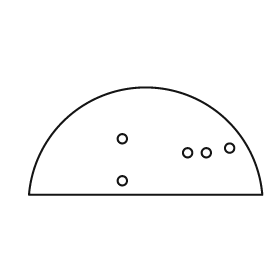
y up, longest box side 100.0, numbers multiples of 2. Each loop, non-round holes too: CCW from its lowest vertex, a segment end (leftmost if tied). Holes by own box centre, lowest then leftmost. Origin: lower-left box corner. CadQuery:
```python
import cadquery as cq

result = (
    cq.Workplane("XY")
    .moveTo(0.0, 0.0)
    .lineTo(100.0, 0.0)
    .threePointArc((50.0, 46.0), (0.0, 0.0))
    .close()
    .moveTo(40.0, 6.0)
    .circle(2.0)
    .moveTo(68.0, 18.0)
    .circle(2.0)
    .moveTo(76.0, 18.0)
    .circle(2.0)
    .moveTo(86.0, 20.0)
    .circle(2.0)
    .moveTo(40.0, 24.0)
    .circle(2.0)
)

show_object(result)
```